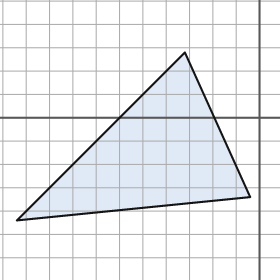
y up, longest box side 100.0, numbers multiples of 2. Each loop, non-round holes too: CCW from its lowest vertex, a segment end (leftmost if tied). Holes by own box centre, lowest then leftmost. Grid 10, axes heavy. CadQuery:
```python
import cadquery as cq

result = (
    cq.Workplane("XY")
    .moveTo(-104.0, -44.0)
    .lineTo(-4.0, -34.0)
    .lineTo(-32.0, 28.0)
    .close()
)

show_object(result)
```